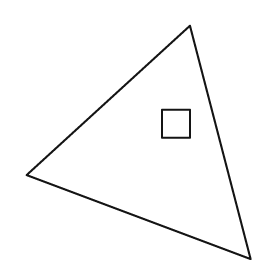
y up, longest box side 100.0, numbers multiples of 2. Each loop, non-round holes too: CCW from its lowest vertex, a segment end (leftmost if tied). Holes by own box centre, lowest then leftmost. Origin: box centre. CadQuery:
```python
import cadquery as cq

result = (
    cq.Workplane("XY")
    .moveTo(48.0, -50.0)
    .lineTo(22.0, 50.0)
    .lineTo(-48.0, -14.0)
    .close()
    .moveTo(10.0, 2.0)
    .lineTo(22.0, 2.0)
    .lineTo(22.0, 14.0)
    .lineTo(10.0, 14.0)
    .close()
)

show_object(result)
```